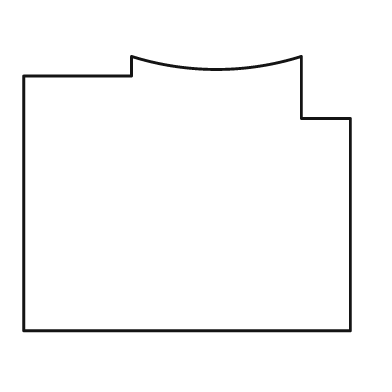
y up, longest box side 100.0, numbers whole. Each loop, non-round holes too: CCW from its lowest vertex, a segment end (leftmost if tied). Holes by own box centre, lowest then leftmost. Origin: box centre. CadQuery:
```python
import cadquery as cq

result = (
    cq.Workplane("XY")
    .moveTo(-50.0, -42.0)
    .lineTo(50.0, -42.0)
    .lineTo(50.0, 23.0)
    .lineTo(35.0, 23.0)
    .lineTo(35.0, 42.0)
    .threePointArc((9.0, 38.0), (-17.0, 42.0))
    .lineTo(-17.0, 36.0)
    .lineTo(-50.0, 36.0)
    .close()
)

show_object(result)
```